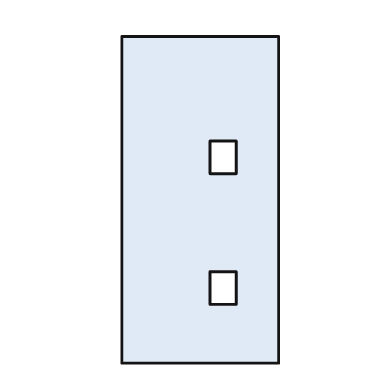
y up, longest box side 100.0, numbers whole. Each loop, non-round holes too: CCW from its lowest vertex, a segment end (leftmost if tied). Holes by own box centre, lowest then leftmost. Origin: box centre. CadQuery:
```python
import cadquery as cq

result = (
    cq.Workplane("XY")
    .moveTo(-24.0, -50.0)
    .lineTo(24.0, -50.0)
    .lineTo(24.0, 50.0)
    .lineTo(-24.0, 50.0)
    .close()
    .moveTo(3.0, -32.0)
    .lineTo(11.0, -32.0)
    .lineTo(11.0, -22.0)
    .lineTo(3.0, -22.0)
    .close()
    .moveTo(3.0, 8.0)
    .lineTo(11.0, 8.0)
    .lineTo(11.0, 18.0)
    .lineTo(3.0, 18.0)
    .close()
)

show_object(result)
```